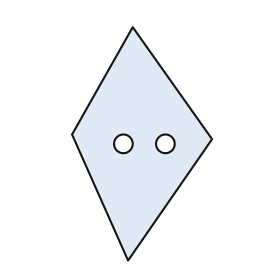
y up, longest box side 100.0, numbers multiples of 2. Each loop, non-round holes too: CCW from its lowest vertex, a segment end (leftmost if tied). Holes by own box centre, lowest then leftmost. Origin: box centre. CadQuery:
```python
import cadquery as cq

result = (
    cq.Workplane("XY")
    .moveTo(-6.0, -50.0)
    .lineTo(30.0, 2.0)
    .lineTo(-4.0, 50.0)
    .lineTo(-30.0, 4.0)
    .close()
    .moveTo(-8.0, 0.0)
    .circle(4.0)
    .moveTo(10.0, 0.0)
    .circle(4.0)
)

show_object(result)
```